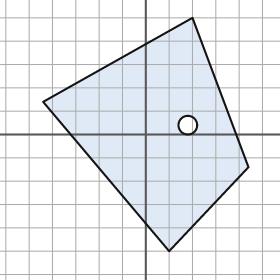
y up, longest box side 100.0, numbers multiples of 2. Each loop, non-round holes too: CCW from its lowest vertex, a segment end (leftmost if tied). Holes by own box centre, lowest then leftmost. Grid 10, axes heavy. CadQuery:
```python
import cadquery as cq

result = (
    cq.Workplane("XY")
    .moveTo(10.0, -50.0)
    .lineTo(44.0, -14.0)
    .lineTo(20.0, 50.0)
    .lineTo(-44.0, 14.0)
    .close()
    .moveTo(18.0, 4.0)
    .circle(4.0)
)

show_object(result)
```